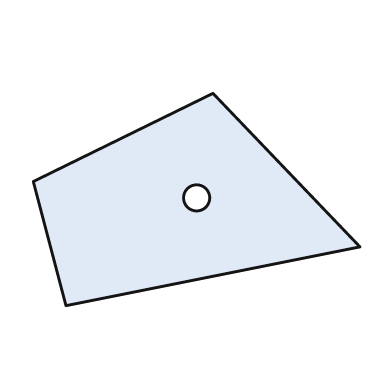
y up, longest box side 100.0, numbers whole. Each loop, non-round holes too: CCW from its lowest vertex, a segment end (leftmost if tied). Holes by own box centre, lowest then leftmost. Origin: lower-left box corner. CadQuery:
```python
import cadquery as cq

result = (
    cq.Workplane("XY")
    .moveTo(10.0, 0.0)
    .lineTo(100.0, 18.0)
    .lineTo(55.0, 65.0)
    .lineTo(0.0, 38.0)
    .close()
    .moveTo(50.0, 33.0)
    .circle(4.0)
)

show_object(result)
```